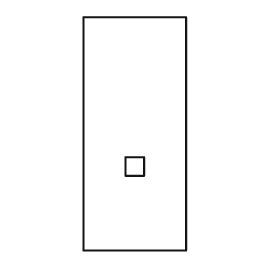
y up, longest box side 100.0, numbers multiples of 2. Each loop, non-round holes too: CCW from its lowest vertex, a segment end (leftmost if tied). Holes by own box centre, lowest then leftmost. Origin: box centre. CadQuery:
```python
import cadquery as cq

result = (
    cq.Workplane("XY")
    .moveTo(-22.0, -50.0)
    .lineTo(22.0, -50.0)
    .lineTo(22.0, 50.0)
    .lineTo(-22.0, 50.0)
    .close()
    .moveTo(-4.0, -18.0)
    .lineTo(4.0, -18.0)
    .lineTo(4.0, -10.0)
    .lineTo(-4.0, -10.0)
    .close()
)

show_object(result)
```